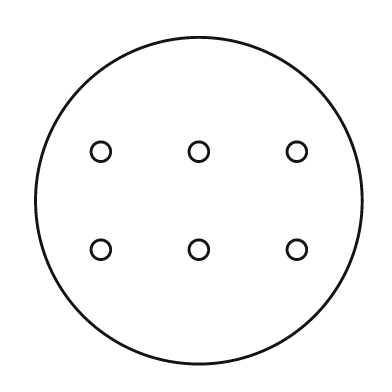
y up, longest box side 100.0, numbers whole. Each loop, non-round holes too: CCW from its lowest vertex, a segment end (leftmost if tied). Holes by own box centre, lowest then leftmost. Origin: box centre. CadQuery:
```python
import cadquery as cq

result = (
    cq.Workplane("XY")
    .moveTo(0.0, 0.0)
    .circle(50.0)
    .moveTo(-30.0, -15.0)
    .circle(3.0)
    .moveTo(0.0, -15.0)
    .circle(3.0)
    .moveTo(30.0, -15.0)
    .circle(3.0)
    .moveTo(-30.0, 15.0)
    .circle(3.0)
    .moveTo(0.0, 15.0)
    .circle(3.0)
    .moveTo(30.0, 15.0)
    .circle(3.0)
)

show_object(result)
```